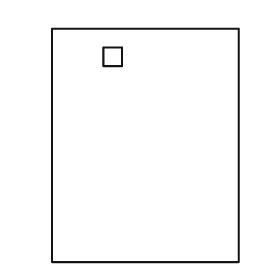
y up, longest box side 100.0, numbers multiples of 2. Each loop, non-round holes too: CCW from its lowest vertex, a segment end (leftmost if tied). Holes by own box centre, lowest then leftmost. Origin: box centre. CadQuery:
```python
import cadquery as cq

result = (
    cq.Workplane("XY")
    .moveTo(-40.0, -50.0)
    .lineTo(40.0, -50.0)
    .lineTo(40.0, 50.0)
    .lineTo(-40.0, 50.0)
    .close()
    .moveTo(-18.0, 34.0)
    .lineTo(-10.0, 34.0)
    .lineTo(-10.0, 42.0)
    .lineTo(-18.0, 42.0)
    .close()
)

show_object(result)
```